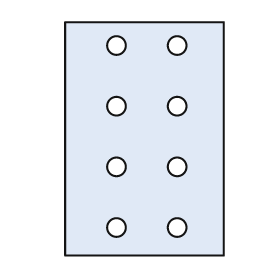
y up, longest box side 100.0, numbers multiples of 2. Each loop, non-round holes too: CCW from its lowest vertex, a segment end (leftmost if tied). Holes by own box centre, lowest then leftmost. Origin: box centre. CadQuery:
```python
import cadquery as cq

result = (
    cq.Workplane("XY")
    .moveTo(-34.0, -50.0)
    .lineTo(34.0, -50.0)
    .lineTo(34.0, 50.0)
    .lineTo(-34.0, 50.0)
    .close()
    .moveTo(-12.0, -38.0)
    .circle(4.0)
    .moveTo(14.0, -38.0)
    .circle(4.0)
    .moveTo(-12.0, -12.0)
    .circle(4.0)
    .moveTo(14.0, -12.0)
    .circle(4.0)
    .moveTo(-12.0, 14.0)
    .circle(4.0)
    .moveTo(14.0, 14.0)
    .circle(4.0)
    .moveTo(-12.0, 40.0)
    .circle(4.0)
    .moveTo(14.0, 40.0)
    .circle(4.0)
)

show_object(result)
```